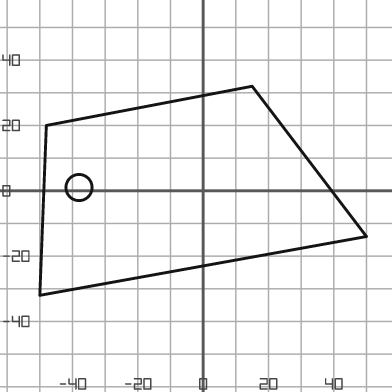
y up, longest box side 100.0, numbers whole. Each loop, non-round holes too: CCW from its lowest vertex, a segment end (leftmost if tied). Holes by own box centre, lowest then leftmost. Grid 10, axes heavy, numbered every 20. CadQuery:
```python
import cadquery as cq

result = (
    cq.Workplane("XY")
    .moveTo(-50.0, -32.0)
    .lineTo(50.0, -14.0)
    .lineTo(15.0, 32.0)
    .lineTo(-48.0, 20.0)
    .close()
    .moveTo(-38.0, 1.0)
    .circle(4.0)
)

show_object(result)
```